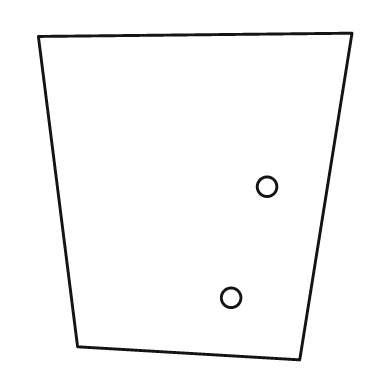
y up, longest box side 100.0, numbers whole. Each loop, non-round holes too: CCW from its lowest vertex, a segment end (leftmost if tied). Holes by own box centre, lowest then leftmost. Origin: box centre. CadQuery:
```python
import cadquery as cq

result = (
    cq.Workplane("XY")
    .moveTo(32.0, -50.0)
    .lineTo(48.0, 50.0)
    .lineTo(-48.0, 49.0)
    .lineTo(-36.0, -46.0)
    .close()
    .moveTo(11.0, -31.0)
    .circle(3.0)
    .moveTo(22.0, 3.0)
    .circle(3.0)
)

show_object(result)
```